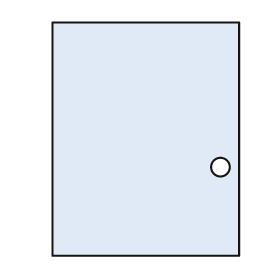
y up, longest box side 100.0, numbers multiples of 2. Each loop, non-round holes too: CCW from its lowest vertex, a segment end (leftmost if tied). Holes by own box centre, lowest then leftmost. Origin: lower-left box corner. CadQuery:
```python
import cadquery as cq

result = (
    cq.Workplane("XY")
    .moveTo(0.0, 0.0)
    .lineTo(80.0, 0.0)
    .lineTo(80.0, 100.0)
    .lineTo(0.0, 100.0)
    .close()
    .moveTo(72.0, 38.0)
    .circle(4.0)
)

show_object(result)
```